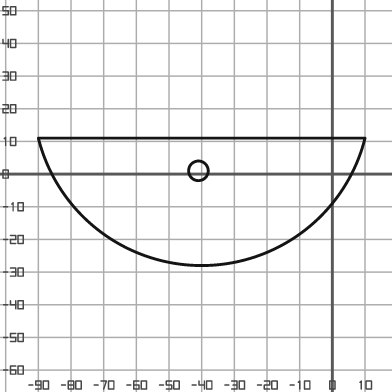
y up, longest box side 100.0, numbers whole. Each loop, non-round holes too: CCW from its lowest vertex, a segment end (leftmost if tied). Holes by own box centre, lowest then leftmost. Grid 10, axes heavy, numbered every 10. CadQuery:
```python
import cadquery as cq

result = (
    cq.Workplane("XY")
    .moveTo(-90.0, 11.0)
    .threePointArc((-40.0, -28.0), (10.0, 11.0))
    .close()
    .moveTo(-41.0, 1.0)
    .circle(3.0)
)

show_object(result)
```